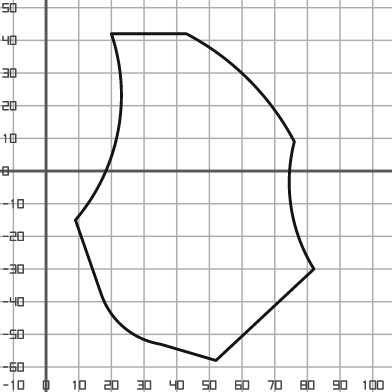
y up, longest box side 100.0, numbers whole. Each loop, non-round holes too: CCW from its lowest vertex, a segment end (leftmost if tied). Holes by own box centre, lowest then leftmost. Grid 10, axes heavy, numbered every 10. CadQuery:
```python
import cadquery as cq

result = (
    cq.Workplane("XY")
    .moveTo(52.0, -58.0)
    .lineTo(82.0, -30.0)
    .threePointArc((75.0, -11.0), (76.0, 9.0))
    .threePointArc((62.0, 28.0), (43.0, 42.0))
    .lineTo(20.0, 42.0)
    .threePointArc((22.0, 12.0), (9.0, -15.0))
    .lineTo(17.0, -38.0)
    .threePointArc((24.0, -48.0), (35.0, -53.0))
    .close()
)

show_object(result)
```